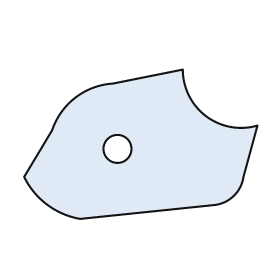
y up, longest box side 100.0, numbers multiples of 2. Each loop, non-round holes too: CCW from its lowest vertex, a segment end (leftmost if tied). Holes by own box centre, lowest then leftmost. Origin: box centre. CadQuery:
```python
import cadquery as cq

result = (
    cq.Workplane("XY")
    .moveTo(-26.0, -32.0)
    .lineTo(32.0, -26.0)
    .threePointArc((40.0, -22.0), (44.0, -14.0))
    .lineTo(50.0, 8.0)
    .threePointArc((28.0, 12.0), (18.0, 32.0))
    .lineTo(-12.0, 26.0)
    .threePointArc((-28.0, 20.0), (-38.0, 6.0))
    .lineTo(-50.0, -14.0)
    .threePointArc((-40.0, -26.0), (-26.0, -32.0))
    .close()
    .moveTo(-10.0, -2.0)
    .circle(6.0)
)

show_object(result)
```